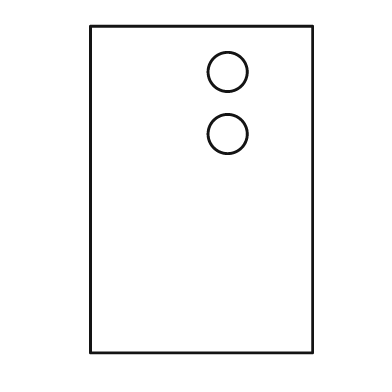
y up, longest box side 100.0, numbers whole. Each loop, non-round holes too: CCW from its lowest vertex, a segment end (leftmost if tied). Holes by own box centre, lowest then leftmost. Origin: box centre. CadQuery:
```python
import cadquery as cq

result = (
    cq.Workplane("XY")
    .moveTo(-34.0, -50.0)
    .lineTo(34.0, -50.0)
    .lineTo(34.0, 50.0)
    .lineTo(-34.0, 50.0)
    .close()
    .moveTo(8.0, 17.0)
    .circle(6.0)
    .moveTo(8.0, 36.0)
    .circle(6.0)
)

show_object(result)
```